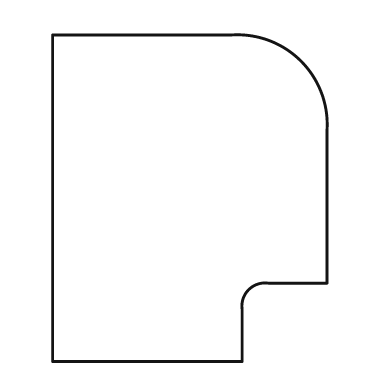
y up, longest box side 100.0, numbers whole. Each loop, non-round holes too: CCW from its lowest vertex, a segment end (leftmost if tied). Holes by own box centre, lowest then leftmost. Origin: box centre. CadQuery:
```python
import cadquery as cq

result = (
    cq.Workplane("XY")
    .moveTo(-42.0, -50.0)
    .lineTo(16.0, -50.0)
    .lineTo(16.0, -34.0)
    .threePointArc((18.0, -28.0), (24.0, -26.0))
    .lineTo(42.0, -26.0)
    .lineTo(42.0, 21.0)
    .threePointArc((34.0, 42.0), (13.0, 50.0))
    .lineTo(-42.0, 50.0)
    .close()
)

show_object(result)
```